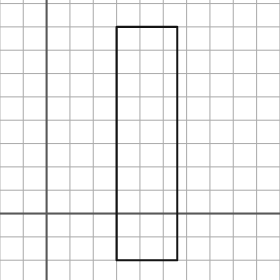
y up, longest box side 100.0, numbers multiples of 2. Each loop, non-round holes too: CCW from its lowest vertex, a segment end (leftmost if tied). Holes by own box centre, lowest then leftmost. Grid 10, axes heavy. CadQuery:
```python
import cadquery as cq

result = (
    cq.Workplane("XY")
    .moveTo(30.0, -20.0)
    .lineTo(56.0, -20.0)
    .lineTo(56.0, 80.0)
    .lineTo(30.0, 80.0)
    .close()
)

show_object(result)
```